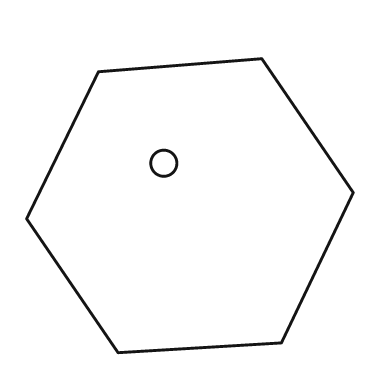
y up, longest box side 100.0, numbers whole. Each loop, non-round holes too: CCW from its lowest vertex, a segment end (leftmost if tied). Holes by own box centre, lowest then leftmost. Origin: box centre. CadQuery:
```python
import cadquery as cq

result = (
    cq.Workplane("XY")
    .moveTo(-22.0, -45.0)
    .lineTo(28.0, -42.0)
    .lineTo(50.0, 4.0)
    .lineTo(22.0, 45.0)
    .lineTo(-28.0, 41.0)
    .lineTo(-50.0, -4.0)
    .close()
    .moveTo(-8.0, 13.0)
    .circle(4.0)
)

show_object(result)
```